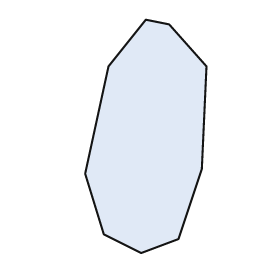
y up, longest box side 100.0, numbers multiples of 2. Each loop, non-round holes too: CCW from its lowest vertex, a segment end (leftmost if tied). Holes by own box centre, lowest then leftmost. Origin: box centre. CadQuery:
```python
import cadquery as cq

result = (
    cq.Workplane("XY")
    .moveTo(-2.0, -50.0)
    .lineTo(14.0, -44.0)
    .lineTo(24.0, -14.0)
    .lineTo(26.0, 30.0)
    .lineTo(10.0, 48.0)
    .lineTo(0.0, 50.0)
    .lineTo(-16.0, 30.0)
    .lineTo(-26.0, -16.0)
    .lineTo(-18.0, -42.0)
    .close()
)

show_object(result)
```